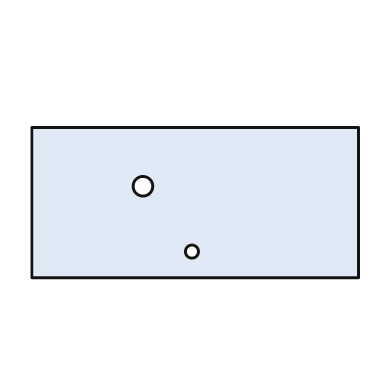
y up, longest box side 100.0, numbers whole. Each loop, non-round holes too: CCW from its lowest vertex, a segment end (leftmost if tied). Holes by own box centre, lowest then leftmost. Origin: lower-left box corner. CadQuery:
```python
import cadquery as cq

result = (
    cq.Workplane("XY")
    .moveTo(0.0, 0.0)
    .lineTo(100.0, 0.0)
    .lineTo(100.0, 46.0)
    .lineTo(0.0, 46.0)
    .close()
    .moveTo(49.0, 8.0)
    .circle(2.0)
    .moveTo(34.0, 28.0)
    .circle(3.0)
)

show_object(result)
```